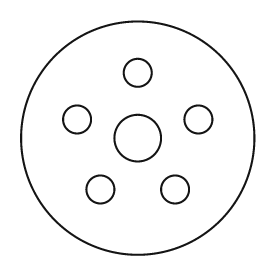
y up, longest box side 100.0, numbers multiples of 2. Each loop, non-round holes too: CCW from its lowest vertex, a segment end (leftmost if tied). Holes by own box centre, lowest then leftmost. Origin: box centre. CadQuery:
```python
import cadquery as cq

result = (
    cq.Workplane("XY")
    .moveTo(0.0, 0.0)
    .circle(50.0)
    .moveTo(-16.0, -22.0)
    .circle(6.0)
    .moveTo(16.0, -22.0)
    .circle(6.0)
    .moveTo(0.0, 0.0)
    .circle(10.0)
    .moveTo(-26.0, 8.0)
    .circle(6.0)
    .moveTo(26.0, 8.0)
    .circle(6.0)
    .moveTo(0.0, 28.0)
    .circle(6.0)
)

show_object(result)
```